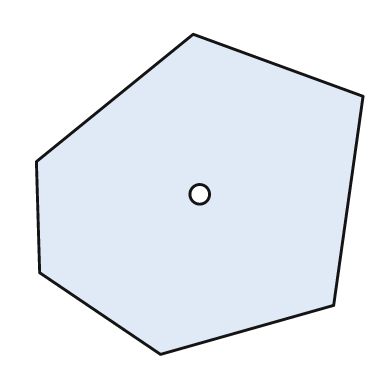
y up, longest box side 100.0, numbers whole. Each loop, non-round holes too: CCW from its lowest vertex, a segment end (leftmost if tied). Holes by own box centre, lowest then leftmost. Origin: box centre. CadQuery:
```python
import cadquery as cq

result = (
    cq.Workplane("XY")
    .moveTo(-12.0, -49.0)
    .lineTo(41.0, -34.0)
    .lineTo(50.0, 30.0)
    .lineTo(-2.0, 49.0)
    .lineTo(-50.0, 10.0)
    .lineTo(-49.0, -24.0)
    .close()
    .moveTo(0.0, 0.0)
    .circle(3.0)
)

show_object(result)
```